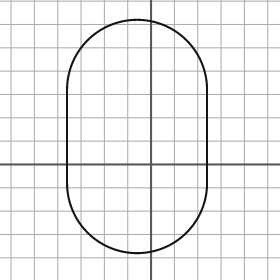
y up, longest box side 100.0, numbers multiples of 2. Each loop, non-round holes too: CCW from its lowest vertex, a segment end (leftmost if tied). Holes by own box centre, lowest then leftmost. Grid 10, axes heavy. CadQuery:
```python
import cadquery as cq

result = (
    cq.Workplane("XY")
    .moveTo(-36.0, -8.0)
    .threePointArc((-6.0, -38.0), (24.0, -8.0))
    .lineTo(24.0, 32.0)
    .threePointArc((-6.0, 62.0), (-36.0, 32.0))
    .close()
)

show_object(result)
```